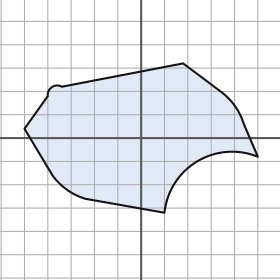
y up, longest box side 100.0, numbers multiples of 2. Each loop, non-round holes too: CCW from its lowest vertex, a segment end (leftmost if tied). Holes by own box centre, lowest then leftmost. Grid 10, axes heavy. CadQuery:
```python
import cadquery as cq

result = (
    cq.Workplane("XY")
    .moveTo(10.0, -32.0)
    .threePointArc((24.0, -10.0), (50.0, -8.0))
    .lineTo(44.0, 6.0)
    .threePointArc((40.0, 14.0), (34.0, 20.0))
    .lineTo(18.0, 32.0)
    .lineTo(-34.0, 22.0)
    .threePointArc((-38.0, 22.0), (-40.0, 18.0))
    .lineTo(-50.0, 4.0)
    .lineTo(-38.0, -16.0)
    .threePointArc((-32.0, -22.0), (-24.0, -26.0))
    .close()
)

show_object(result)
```